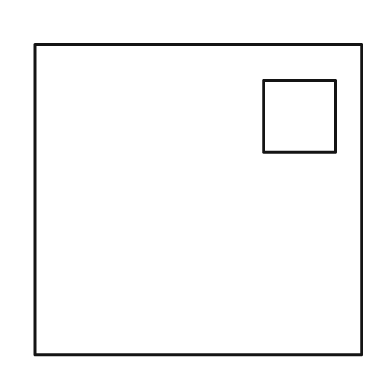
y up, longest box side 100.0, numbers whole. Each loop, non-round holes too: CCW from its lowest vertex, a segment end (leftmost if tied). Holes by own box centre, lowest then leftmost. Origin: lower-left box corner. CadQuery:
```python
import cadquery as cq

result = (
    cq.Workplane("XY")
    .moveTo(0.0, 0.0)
    .lineTo(100.0, 0.0)
    .lineTo(100.0, 95.0)
    .lineTo(0.0, 95.0)
    .close()
    .moveTo(70.0, 62.0)
    .lineTo(92.0, 62.0)
    .lineTo(92.0, 84.0)
    .lineTo(70.0, 84.0)
    .close()
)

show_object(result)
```